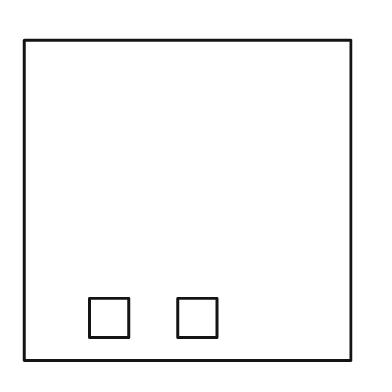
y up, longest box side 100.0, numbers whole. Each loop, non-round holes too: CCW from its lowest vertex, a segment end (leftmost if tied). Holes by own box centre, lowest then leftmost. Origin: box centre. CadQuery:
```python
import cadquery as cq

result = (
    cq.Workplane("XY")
    .moveTo(-50.0, -49.0)
    .lineTo(50.0, -49.0)
    .lineTo(50.0, 49.0)
    .lineTo(-50.0, 49.0)
    .close()
    .moveTo(-30.0, -42.0)
    .lineTo(-18.0, -42.0)
    .lineTo(-18.0, -30.0)
    .lineTo(-30.0, -30.0)
    .close()
    .moveTo(-3.0, -42.0)
    .lineTo(9.0, -42.0)
    .lineTo(9.0, -30.0)
    .lineTo(-3.0, -30.0)
    .close()
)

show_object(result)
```